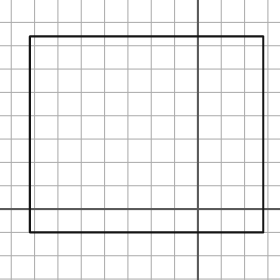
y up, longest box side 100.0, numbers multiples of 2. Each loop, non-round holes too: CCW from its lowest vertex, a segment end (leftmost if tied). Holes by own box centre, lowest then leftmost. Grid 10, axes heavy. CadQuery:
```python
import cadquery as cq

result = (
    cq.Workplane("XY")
    .moveTo(-72.0, -10.0)
    .lineTo(28.0, -10.0)
    .lineTo(28.0, 74.0)
    .lineTo(-72.0, 74.0)
    .close()
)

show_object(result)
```